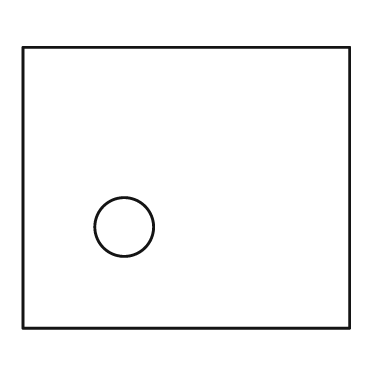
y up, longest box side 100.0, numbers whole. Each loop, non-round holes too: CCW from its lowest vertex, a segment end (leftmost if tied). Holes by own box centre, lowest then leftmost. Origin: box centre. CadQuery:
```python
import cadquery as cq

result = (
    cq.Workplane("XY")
    .moveTo(-50.0, -43.0)
    .lineTo(50.0, -43.0)
    .lineTo(50.0, 43.0)
    .lineTo(-50.0, 43.0)
    .close()
    .moveTo(-19.0, -12.0)
    .circle(9.0)
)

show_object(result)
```